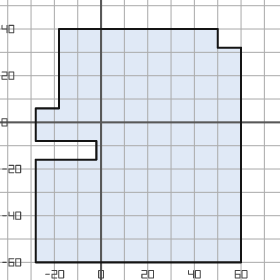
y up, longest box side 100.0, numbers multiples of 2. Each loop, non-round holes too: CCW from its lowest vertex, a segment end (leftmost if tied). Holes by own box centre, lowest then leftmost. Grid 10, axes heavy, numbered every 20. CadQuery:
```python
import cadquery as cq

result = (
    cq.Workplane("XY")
    .moveTo(-28.0, -60.0)
    .lineTo(60.0, -60.0)
    .lineTo(60.0, 32.0)
    .lineTo(50.0, 32.0)
    .lineTo(50.0, 40.0)
    .lineTo(-18.0, 40.0)
    .lineTo(-18.0, 6.0)
    .lineTo(-28.0, 6.0)
    .lineTo(-28.0, -8.0)
    .lineTo(-2.0, -8.0)
    .lineTo(-2.0, -16.0)
    .lineTo(-28.0, -16.0)
    .close()
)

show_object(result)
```